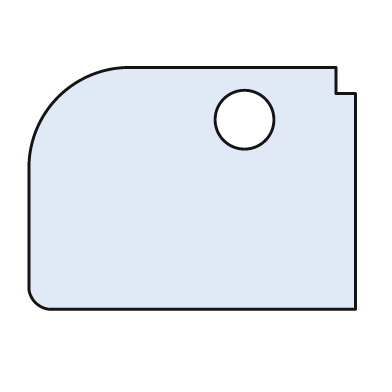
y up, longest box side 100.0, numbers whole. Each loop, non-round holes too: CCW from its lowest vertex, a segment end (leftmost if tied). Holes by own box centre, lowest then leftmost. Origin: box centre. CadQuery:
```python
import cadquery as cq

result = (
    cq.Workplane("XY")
    .moveTo(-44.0, -37.0)
    .lineTo(50.0, -37.0)
    .lineTo(50.0, 29.0)
    .lineTo(44.0, 29.0)
    .lineTo(44.0, 37.0)
    .lineTo(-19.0, 37.0)
    .threePointArc((-41.0, 28.0), (-50.0, 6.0))
    .lineTo(-50.0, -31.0)
    .threePointArc((-48.0, -35.0), (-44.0, -37.0))
    .close()
    .moveTo(16.0, 21.0)
    .circle(9.0)
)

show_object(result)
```